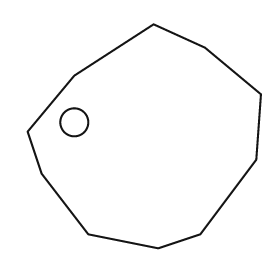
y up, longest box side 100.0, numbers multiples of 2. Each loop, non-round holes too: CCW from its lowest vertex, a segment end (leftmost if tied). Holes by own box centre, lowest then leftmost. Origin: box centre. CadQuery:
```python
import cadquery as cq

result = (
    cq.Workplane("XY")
    .moveTo(6.0, -48.0)
    .lineTo(24.0, -42.0)
    .lineTo(48.0, -10.0)
    .lineTo(50.0, 18.0)
    .lineTo(26.0, 38.0)
    .lineTo(4.0, 48.0)
    .lineTo(-30.0, 26.0)
    .lineTo(-50.0, 2.0)
    .lineTo(-44.0, -16.0)
    .lineTo(-24.0, -42.0)
    .close()
    .moveTo(-30.0, 6.0)
    .circle(6.0)
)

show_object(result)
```